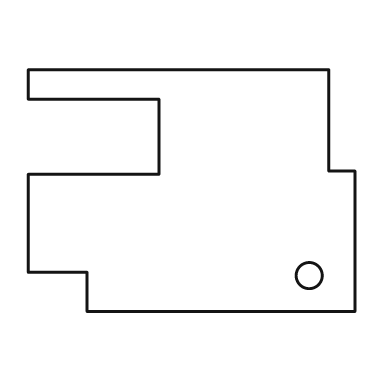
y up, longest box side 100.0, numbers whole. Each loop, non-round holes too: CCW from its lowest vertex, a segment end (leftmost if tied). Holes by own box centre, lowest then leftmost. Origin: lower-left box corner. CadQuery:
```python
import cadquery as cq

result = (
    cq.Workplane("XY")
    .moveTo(18.0, 0.0)
    .lineTo(100.0, 0.0)
    .lineTo(100.0, 43.0)
    .lineTo(92.0, 43.0)
    .lineTo(92.0, 74.0)
    .lineTo(0.0, 74.0)
    .lineTo(0.0, 65.0)
    .lineTo(40.0, 65.0)
    .lineTo(40.0, 42.0)
    .lineTo(0.0, 42.0)
    .lineTo(0.0, 12.0)
    .lineTo(18.0, 12.0)
    .close()
    .moveTo(86.0, 11.0)
    .circle(4.0)
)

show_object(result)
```